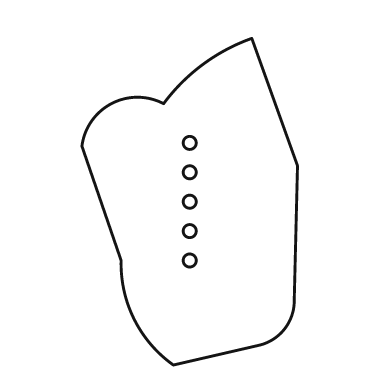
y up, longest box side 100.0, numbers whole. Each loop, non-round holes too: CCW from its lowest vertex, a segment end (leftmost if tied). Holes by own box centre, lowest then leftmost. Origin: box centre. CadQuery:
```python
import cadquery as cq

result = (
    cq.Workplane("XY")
    .moveTo(-5.0, -50.0)
    .lineTo(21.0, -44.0)
    .threePointArc((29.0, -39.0), (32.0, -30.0))
    .lineTo(33.0, 11.0)
    .lineTo(19.0, 50.0)
    .threePointArc((4.0, 42.0), (-8.0, 30.0))
    .threePointArc((-24.0, 30.0), (-33.0, 17.0))
    .lineTo(-21.0, -18.0)
    .threePointArc((-17.0, -36.0), (-5.0, -50.0))
    .close()
    .moveTo(0.0, -18.0)
    .circle(2.0)
    .moveTo(0.0, -9.0)
    .circle(2.0)
    .moveTo(0.0, 0.0)
    .circle(2.0)
    .moveTo(0.0, 9.0)
    .circle(2.0)
    .moveTo(0.0, 18.0)
    .circle(2.0)
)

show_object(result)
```